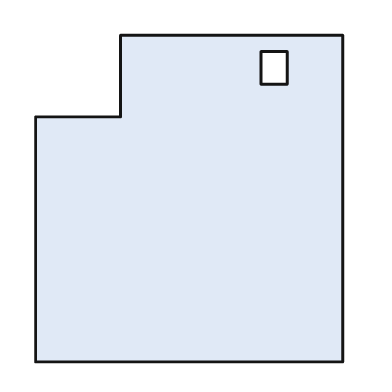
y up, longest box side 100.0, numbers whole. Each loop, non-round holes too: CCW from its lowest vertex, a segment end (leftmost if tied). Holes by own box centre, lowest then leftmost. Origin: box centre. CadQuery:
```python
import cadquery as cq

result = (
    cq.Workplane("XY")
    .moveTo(-47.0, -50.0)
    .lineTo(47.0, -50.0)
    .lineTo(47.0, 50.0)
    .lineTo(-21.0, 50.0)
    .lineTo(-21.0, 25.0)
    .lineTo(-47.0, 25.0)
    .close()
    .moveTo(22.0, 35.0)
    .lineTo(30.0, 35.0)
    .lineTo(30.0, 45.0)
    .lineTo(22.0, 45.0)
    .close()
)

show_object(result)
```